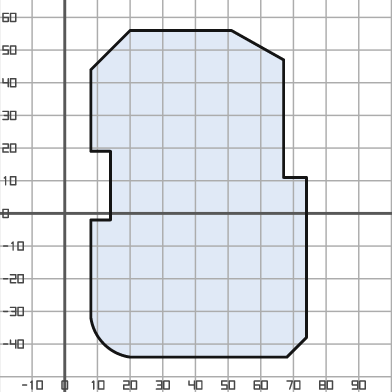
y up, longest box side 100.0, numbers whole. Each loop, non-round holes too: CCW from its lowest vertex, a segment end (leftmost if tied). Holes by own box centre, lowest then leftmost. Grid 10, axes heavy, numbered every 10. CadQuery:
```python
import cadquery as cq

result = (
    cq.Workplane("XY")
    .moveTo(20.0, -44.0)
    .lineTo(68.0, -44.0)
    .lineTo(74.0, -38.0)
    .lineTo(74.0, 11.0)
    .lineTo(67.0, 11.0)
    .lineTo(67.0, 47.0)
    .lineTo(51.0, 56.0)
    .lineTo(20.0, 56.0)
    .lineTo(8.0, 44.0)
    .lineTo(8.0, 19.0)
    .lineTo(14.0, 19.0)
    .lineTo(14.0, -2.0)
    .lineTo(8.0, -2.0)
    .lineTo(8.0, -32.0)
    .threePointArc((12.0, -40.0), (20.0, -44.0))
    .close()
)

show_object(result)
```